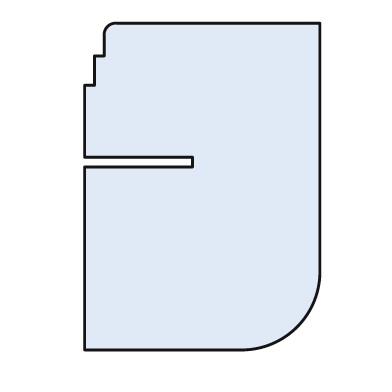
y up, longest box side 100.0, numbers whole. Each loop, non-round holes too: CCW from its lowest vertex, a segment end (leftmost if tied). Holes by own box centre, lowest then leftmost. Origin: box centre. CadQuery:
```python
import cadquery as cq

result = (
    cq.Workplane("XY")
    .moveTo(-36.0, -50.0)
    .lineTo(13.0, -50.0)
    .threePointArc((29.0, -43.0), (36.0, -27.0))
    .lineTo(36.0, 50.0)
    .lineTo(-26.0, 50.0)
    .threePointArc((-29.0, 49.0), (-30.0, 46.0))
    .lineTo(-30.0, 40.0)
    .lineTo(-33.0, 40.0)
    .lineTo(-33.0, 31.0)
    .lineTo(-36.0, 31.0)
    .lineTo(-36.0, 9.0)
    .lineTo(-3.0, 9.0)
    .lineTo(-3.0, 6.0)
    .lineTo(-36.0, 6.0)
    .close()
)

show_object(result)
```